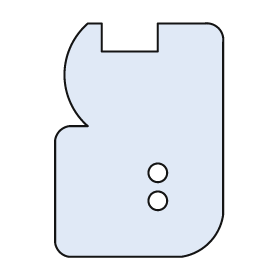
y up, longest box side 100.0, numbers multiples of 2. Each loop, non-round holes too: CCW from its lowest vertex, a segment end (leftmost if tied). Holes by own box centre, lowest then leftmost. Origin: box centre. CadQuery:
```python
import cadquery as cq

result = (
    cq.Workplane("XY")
    .moveTo(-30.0, -50.0)
    .lineTo(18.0, -50.0)
    .threePointArc((30.0, -44.0), (36.0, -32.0))
    .lineTo(36.0, 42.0)
    .threePointArc((34.0, 48.0), (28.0, 50.0))
    .lineTo(8.0, 50.0)
    .lineTo(8.0, 38.0)
    .lineTo(-16.0, 38.0)
    .lineTo(-16.0, 50.0)
    .lineTo(-22.0, 50.0)
    .threePointArc((-32.0, 28.0), (-22.0, 6.0))
    .lineTo(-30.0, 6.0)
    .threePointArc((-34.0, 4.0), (-36.0, 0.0))
    .lineTo(-36.0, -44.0)
    .threePointArc((-34.0, -48.0), (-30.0, -50.0))
    .close()
    .moveTo(8.0, -26.0)
    .circle(4.0)
    .moveTo(8.0, -14.0)
    .circle(4.0)
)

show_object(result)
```